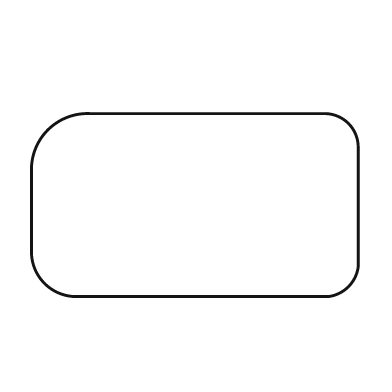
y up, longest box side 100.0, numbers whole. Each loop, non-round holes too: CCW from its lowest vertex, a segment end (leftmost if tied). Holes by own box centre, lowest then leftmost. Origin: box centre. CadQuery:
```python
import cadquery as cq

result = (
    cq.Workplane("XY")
    .moveTo(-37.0, -28.0)
    .lineTo(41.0, -28.0)
    .threePointArc((47.0, -25.0), (50.0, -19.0))
    .lineTo(50.0, 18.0)
    .threePointArc((47.0, 25.0), (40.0, 28.0))
    .lineTo(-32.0, 28.0)
    .threePointArc((-45.0, 23.0), (-50.0, 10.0))
    .lineTo(-50.0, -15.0)
    .threePointArc((-46.0, -24.0), (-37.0, -28.0))
    .close()
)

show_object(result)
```